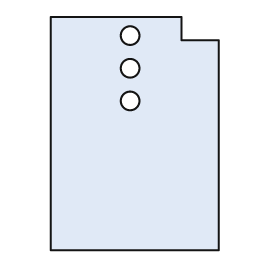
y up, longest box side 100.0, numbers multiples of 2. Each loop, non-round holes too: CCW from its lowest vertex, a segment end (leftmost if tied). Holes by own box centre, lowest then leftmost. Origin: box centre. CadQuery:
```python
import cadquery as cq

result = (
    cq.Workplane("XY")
    .moveTo(-36.0, -50.0)
    .lineTo(36.0, -50.0)
    .lineTo(36.0, 40.0)
    .lineTo(20.0, 40.0)
    .lineTo(20.0, 50.0)
    .lineTo(-36.0, 50.0)
    .close()
    .moveTo(-2.0, 14.0)
    .circle(4.0)
    .moveTo(-2.0, 28.0)
    .circle(4.0)
    .moveTo(-2.0, 42.0)
    .circle(4.0)
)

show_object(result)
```